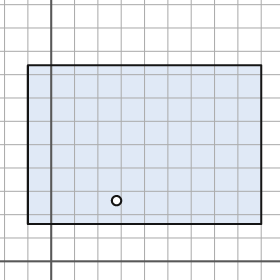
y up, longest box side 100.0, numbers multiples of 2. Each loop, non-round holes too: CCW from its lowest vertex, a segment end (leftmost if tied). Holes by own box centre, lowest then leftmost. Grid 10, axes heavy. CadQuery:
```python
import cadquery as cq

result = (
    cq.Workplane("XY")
    .moveTo(-10.0, 16.0)
    .lineTo(90.0, 16.0)
    .lineTo(90.0, 84.0)
    .lineTo(-10.0, 84.0)
    .close()
    .moveTo(28.0, 26.0)
    .circle(2.0)
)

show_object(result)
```